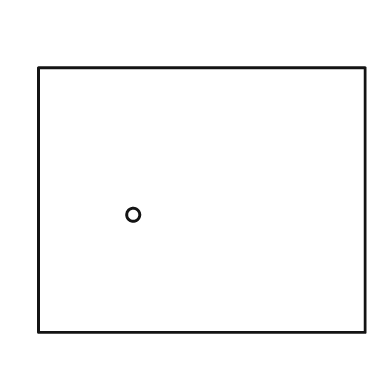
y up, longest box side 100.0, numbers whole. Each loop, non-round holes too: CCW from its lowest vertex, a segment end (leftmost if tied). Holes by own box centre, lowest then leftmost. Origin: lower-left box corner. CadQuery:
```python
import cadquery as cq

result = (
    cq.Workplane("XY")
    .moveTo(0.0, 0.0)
    .lineTo(100.0, 0.0)
    .lineTo(100.0, 81.0)
    .lineTo(0.0, 81.0)
    .close()
    .moveTo(29.0, 36.0)
    .circle(2.0)
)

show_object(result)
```